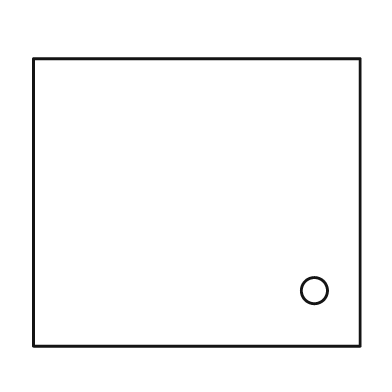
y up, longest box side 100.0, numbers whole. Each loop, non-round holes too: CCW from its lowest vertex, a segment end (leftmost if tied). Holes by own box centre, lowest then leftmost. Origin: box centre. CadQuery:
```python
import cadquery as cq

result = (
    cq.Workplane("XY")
    .moveTo(-50.0, -44.0)
    .lineTo(50.0, -44.0)
    .lineTo(50.0, 44.0)
    .lineTo(-50.0, 44.0)
    .close()
    .moveTo(36.0, -27.0)
    .circle(4.0)
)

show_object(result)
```